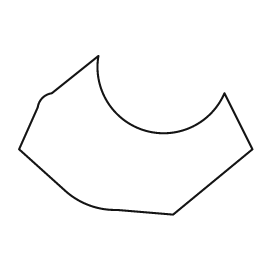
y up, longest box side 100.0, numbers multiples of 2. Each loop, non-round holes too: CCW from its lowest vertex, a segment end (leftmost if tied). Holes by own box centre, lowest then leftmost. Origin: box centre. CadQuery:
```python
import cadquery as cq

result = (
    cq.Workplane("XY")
    .moveTo(16.0, -34.0)
    .lineTo(50.0, -6.0)
    .lineTo(38.0, 18.0)
    .threePointArc((4.0, 2.0), (-16.0, 34.0))
    .lineTo(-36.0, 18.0)
    .threePointArc((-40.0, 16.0), (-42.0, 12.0))
    .lineTo(-50.0, -6.0)
    .lineTo(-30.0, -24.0)
    .threePointArc((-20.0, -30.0), (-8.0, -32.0))
    .close()
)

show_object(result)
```